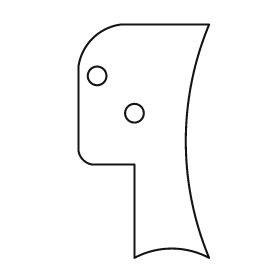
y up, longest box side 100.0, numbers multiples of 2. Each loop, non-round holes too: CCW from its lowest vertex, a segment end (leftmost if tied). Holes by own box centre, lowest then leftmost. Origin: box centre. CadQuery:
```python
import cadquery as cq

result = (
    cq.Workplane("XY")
    .moveTo(-4.0, -50.0)
    .threePointArc((12.0, -46.0), (28.0, -50.0))
    .threePointArc((18.0, 0.0), (28.0, 50.0))
    .lineTo(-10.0, 50.0)
    .threePointArc((-22.0, 44.0), (-28.0, 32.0))
    .lineTo(-28.0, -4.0)
    .threePointArc((-26.0, -8.0), (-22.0, -10.0))
    .lineTo(-4.0, -10.0)
    .close()
    .moveTo(-4.0, 12.0)
    .circle(4.0)
    .moveTo(-20.0, 28.0)
    .circle(4.0)
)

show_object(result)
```